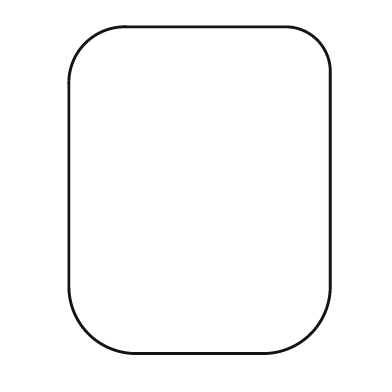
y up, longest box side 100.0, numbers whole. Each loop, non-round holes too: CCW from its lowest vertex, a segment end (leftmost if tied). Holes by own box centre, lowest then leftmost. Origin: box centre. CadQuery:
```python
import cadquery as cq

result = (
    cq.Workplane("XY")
    .moveTo(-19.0, -50.0)
    .lineTo(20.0, -50.0)
    .threePointArc((34.0, -44.0), (40.0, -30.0))
    .lineTo(40.0, 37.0)
    .threePointArc((36.0, 46.0), (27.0, 50.0))
    .lineTo(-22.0, 50.0)
    .threePointArc((-35.0, 45.0), (-40.0, 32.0))
    .lineTo(-40.0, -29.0)
    .threePointArc((-34.0, -44.0), (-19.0, -50.0))
    .close()
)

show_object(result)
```